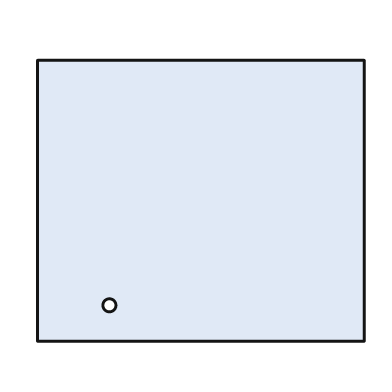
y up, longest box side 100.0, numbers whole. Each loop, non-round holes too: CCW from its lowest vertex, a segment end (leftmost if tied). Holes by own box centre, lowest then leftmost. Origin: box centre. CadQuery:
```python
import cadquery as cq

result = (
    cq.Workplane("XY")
    .moveTo(-50.0, -43.0)
    .lineTo(50.0, -43.0)
    .lineTo(50.0, 43.0)
    .lineTo(-50.0, 43.0)
    .close()
    .moveTo(-28.0, -32.0)
    .circle(2.0)
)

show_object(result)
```